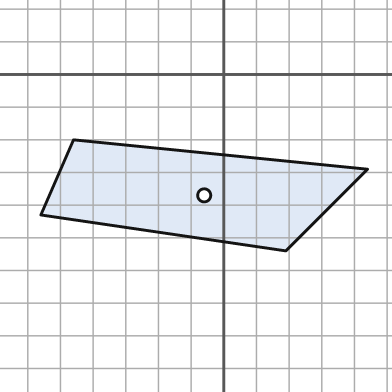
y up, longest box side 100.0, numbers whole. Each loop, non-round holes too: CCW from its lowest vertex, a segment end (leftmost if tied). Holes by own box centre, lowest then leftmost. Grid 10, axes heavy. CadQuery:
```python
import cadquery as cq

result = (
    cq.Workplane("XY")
    .moveTo(19.0, -54.0)
    .lineTo(44.0, -29.0)
    .lineTo(-46.0, -20.0)
    .lineTo(-56.0, -43.0)
    .close()
    .moveTo(-6.0, -37.0)
    .circle(2.0)
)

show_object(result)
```